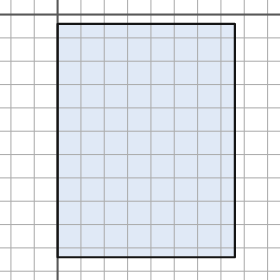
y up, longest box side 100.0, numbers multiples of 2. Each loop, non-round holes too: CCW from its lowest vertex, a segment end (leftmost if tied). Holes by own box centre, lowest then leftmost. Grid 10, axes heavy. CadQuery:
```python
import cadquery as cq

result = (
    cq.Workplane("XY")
    .moveTo(0.0, -104.0)
    .lineTo(76.0, -104.0)
    .lineTo(76.0, -4.0)
    .lineTo(0.0, -4.0)
    .close()
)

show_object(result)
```